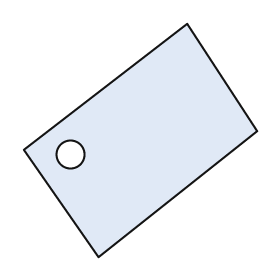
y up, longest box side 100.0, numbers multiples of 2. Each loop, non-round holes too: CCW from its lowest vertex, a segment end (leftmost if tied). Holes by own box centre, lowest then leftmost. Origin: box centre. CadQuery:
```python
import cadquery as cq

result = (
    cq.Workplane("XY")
    .moveTo(-18.0, -50.0)
    .lineTo(50.0, 4.0)
    .lineTo(20.0, 50.0)
    .lineTo(-50.0, -4.0)
    .close()
    .moveTo(-30.0, -6.0)
    .circle(6.0)
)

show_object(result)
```